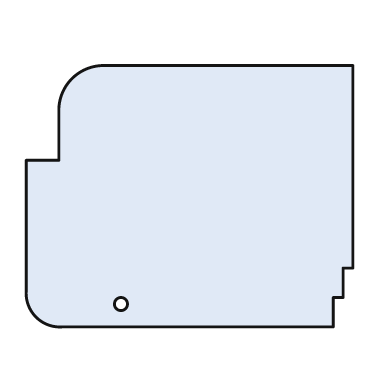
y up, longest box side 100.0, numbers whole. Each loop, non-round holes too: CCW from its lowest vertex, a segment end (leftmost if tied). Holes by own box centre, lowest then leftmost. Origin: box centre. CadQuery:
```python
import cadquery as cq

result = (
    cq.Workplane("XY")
    .moveTo(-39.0, -40.0)
    .lineTo(44.0, -40.0)
    .lineTo(44.0, -31.0)
    .lineTo(47.0, -31.0)
    .lineTo(47.0, -22.0)
    .lineTo(50.0, -22.0)
    .lineTo(50.0, 40.0)
    .lineTo(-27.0, 40.0)
    .threePointArc((-36.0, 36.0), (-40.0, 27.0))
    .lineTo(-40.0, 11.0)
    .lineTo(-50.0, 11.0)
    .lineTo(-50.0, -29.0)
    .threePointArc((-47.0, -37.0), (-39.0, -40.0))
    .close()
    .moveTo(-21.0, -33.0)
    .circle(2.0)
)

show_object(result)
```